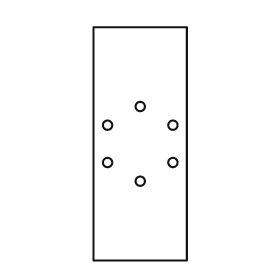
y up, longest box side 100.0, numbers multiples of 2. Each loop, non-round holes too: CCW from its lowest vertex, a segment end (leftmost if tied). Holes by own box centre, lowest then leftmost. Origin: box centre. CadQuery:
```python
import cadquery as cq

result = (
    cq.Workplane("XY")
    .moveTo(-20.0, -50.0)
    .lineTo(20.0, -50.0)
    .lineTo(20.0, 50.0)
    .lineTo(-20.0, 50.0)
    .close()
    .moveTo(0.0, -16.0)
    .circle(2.0)
    .moveTo(-14.0, -8.0)
    .circle(2.0)
    .moveTo(14.0, -8.0)
    .circle(2.0)
    .moveTo(-14.0, 8.0)
    .circle(2.0)
    .moveTo(14.0, 8.0)
    .circle(2.0)
    .moveTo(0.0, 16.0)
    .circle(2.0)
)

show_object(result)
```